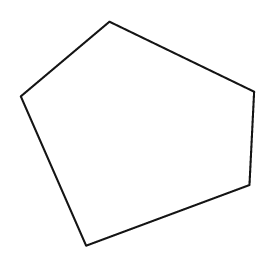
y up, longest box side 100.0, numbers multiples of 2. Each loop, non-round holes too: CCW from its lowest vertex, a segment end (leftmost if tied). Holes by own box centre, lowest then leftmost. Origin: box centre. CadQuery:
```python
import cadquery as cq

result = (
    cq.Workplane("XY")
    .moveTo(-22.0, -48.0)
    .lineTo(48.0, -22.0)
    .lineTo(50.0, 18.0)
    .lineTo(-12.0, 48.0)
    .lineTo(-50.0, 16.0)
    .close()
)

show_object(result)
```